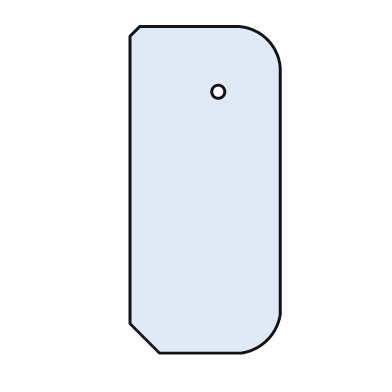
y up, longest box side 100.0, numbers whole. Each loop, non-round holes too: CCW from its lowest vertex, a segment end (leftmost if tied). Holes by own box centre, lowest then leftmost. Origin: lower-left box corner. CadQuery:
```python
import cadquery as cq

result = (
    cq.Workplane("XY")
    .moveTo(9.0, 0.0)
    .lineTo(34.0, 0.0)
    .threePointArc((42.0, 4.0), (46.0, 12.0))
    .lineTo(46.0, 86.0)
    .threePointArc((42.0, 96.0), (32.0, 100.0))
    .lineTo(3.0, 100.0)
    .lineTo(0.0, 97.0)
    .lineTo(0.0, 9.0)
    .close()
    .moveTo(27.0, 80.0)
    .circle(2.0)
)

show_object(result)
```